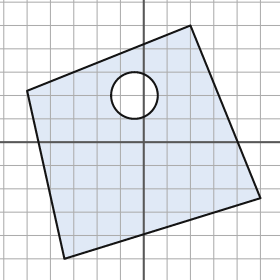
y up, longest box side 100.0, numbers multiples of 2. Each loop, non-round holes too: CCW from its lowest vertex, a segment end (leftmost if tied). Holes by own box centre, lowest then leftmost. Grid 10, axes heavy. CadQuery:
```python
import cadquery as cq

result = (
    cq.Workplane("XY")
    .moveTo(-34.0, -50.0)
    .lineTo(50.0, -24.0)
    .lineTo(20.0, 50.0)
    .lineTo(-50.0, 22.0)
    .close()
    .moveTo(-4.0, 20.0)
    .circle(10.0)
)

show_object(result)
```